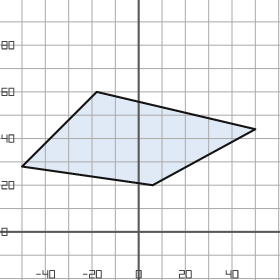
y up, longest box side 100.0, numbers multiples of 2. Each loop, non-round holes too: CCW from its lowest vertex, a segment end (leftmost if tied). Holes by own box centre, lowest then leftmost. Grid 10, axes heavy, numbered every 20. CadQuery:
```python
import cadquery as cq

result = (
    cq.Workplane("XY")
    .moveTo(6.0, 20.0)
    .lineTo(50.0, 44.0)
    .lineTo(-18.0, 60.0)
    .lineTo(-50.0, 28.0)
    .close()
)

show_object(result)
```